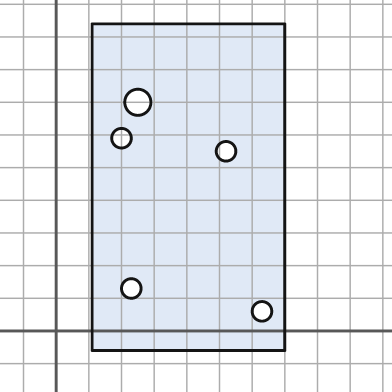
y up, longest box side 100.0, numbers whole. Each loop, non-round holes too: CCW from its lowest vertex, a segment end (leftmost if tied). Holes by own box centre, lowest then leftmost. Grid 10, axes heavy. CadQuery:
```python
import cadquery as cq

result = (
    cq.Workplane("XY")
    .moveTo(11.0, -6.0)
    .lineTo(70.0, -6.0)
    .lineTo(70.0, 94.0)
    .lineTo(11.0, 94.0)
    .close()
    .moveTo(63.0, 6.0)
    .circle(3.0)
    .moveTo(23.0, 13.0)
    .circle(3.0)
    .moveTo(52.0, 55.0)
    .circle(3.0)
    .moveTo(20.0, 59.0)
    .circle(3.0)
    .moveTo(25.0, 70.0)
    .circle(4.0)
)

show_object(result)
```